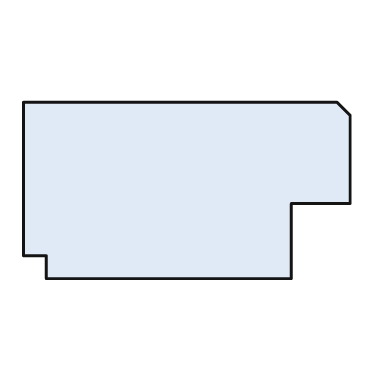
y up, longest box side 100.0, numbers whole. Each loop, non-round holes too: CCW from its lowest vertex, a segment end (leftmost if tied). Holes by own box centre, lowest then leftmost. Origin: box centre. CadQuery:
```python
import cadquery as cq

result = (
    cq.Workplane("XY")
    .moveTo(-43.0, -27.0)
    .lineTo(32.0, -27.0)
    .lineTo(32.0, -4.0)
    .lineTo(50.0, -4.0)
    .lineTo(50.0, 23.0)
    .lineTo(46.0, 27.0)
    .lineTo(-50.0, 27.0)
    .lineTo(-50.0, -20.0)
    .lineTo(-43.0, -20.0)
    .close()
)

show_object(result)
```